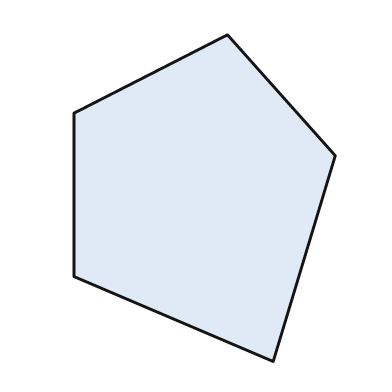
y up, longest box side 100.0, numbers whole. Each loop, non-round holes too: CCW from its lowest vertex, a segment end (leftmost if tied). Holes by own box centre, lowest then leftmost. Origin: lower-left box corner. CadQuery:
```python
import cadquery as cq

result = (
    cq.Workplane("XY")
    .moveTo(61.0, 0.0)
    .lineTo(80.0, 63.0)
    .lineTo(47.0, 100.0)
    .lineTo(0.0, 76.0)
    .lineTo(0.0, 26.0)
    .close()
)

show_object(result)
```